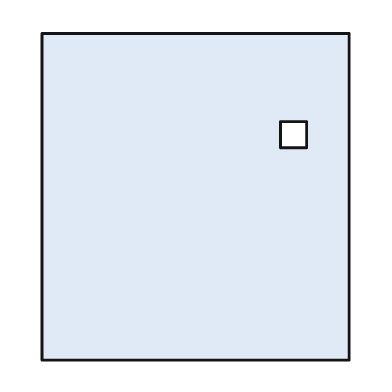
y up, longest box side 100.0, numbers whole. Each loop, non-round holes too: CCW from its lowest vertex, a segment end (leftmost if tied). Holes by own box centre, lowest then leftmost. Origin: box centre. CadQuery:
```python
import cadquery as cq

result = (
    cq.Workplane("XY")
    .moveTo(-47.0, -50.0)
    .lineTo(47.0, -50.0)
    .lineTo(47.0, 50.0)
    .lineTo(-47.0, 50.0)
    .close()
    .moveTo(26.0, 15.0)
    .lineTo(34.0, 15.0)
    .lineTo(34.0, 23.0)
    .lineTo(26.0, 23.0)
    .close()
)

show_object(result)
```